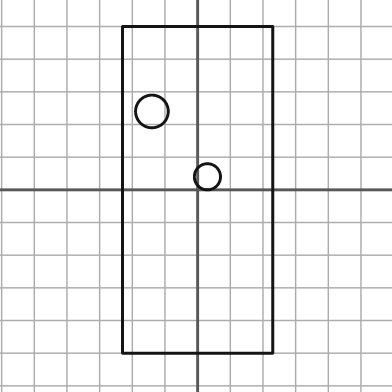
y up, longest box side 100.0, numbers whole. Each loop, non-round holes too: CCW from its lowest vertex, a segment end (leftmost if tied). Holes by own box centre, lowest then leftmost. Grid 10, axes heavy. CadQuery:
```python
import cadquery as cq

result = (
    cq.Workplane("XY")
    .moveTo(-23.0, -50.0)
    .lineTo(23.0, -50.0)
    .lineTo(23.0, 50.0)
    .lineTo(-23.0, 50.0)
    .close()
    .moveTo(3.0, 4.0)
    .circle(4.0)
    .moveTo(-14.0, 24.0)
    .circle(5.0)
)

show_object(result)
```